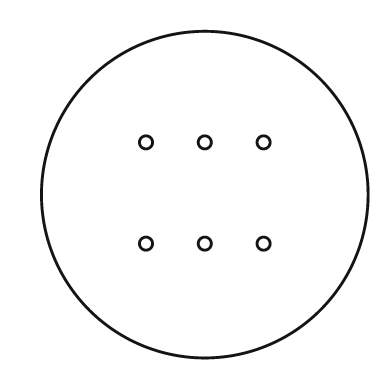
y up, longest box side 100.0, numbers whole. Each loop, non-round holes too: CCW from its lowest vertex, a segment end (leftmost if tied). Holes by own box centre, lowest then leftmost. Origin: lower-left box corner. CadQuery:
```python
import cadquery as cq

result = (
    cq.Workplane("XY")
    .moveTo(50.0, 50.0)
    .circle(50.0)
    .moveTo(32.0, 35.0)
    .circle(2.0)
    .moveTo(50.0, 35.0)
    .circle(2.0)
    .moveTo(68.0, 35.0)
    .circle(2.0)
    .moveTo(32.0, 66.0)
    .circle(2.0)
    .moveTo(50.0, 66.0)
    .circle(2.0)
    .moveTo(68.0, 66.0)
    .circle(2.0)
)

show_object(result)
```